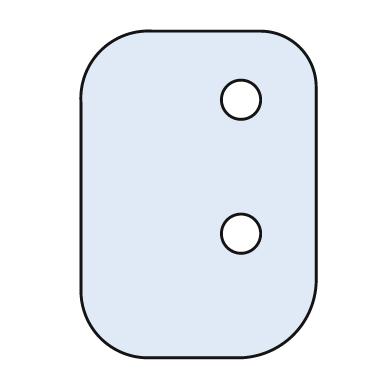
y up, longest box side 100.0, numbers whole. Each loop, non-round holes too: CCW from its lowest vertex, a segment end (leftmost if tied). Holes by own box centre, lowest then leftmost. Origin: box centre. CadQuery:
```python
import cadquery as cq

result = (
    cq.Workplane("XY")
    .moveTo(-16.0, -50.0)
    .lineTo(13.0, -50.0)
    .threePointArc((29.0, -43.0), (36.0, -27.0))
    .lineTo(36.0, 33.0)
    .threePointArc((31.0, 45.0), (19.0, 50.0))
    .lineTo(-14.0, 50.0)
    .threePointArc((-30.0, 44.0), (-36.0, 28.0))
    .lineTo(-36.0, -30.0)
    .threePointArc((-30.0, -44.0), (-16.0, -50.0))
    .close()
    .moveTo(13.0, -12.0)
    .circle(6.0)
    .moveTo(13.0, 29.0)
    .circle(6.0)
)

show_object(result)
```